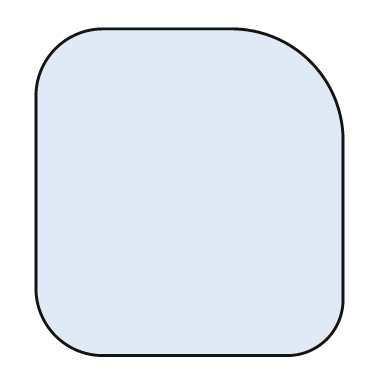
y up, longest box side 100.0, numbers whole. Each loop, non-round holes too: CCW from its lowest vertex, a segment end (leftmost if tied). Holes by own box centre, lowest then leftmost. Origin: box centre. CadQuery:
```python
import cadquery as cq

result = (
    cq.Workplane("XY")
    .moveTo(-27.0, -50.0)
    .lineTo(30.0, -50.0)
    .threePointArc((42.0, -45.0), (47.0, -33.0))
    .lineTo(47.0, 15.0)
    .threePointArc((37.0, 40.0), (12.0, 50.0))
    .lineTo(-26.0, 50.0)
    .threePointArc((-41.0, 44.0), (-47.0, 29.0))
    .lineTo(-47.0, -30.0)
    .threePointArc((-41.0, -44.0), (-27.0, -50.0))
    .close()
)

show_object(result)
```